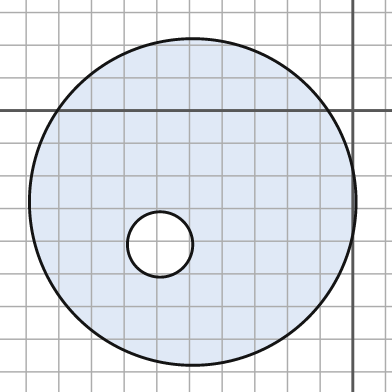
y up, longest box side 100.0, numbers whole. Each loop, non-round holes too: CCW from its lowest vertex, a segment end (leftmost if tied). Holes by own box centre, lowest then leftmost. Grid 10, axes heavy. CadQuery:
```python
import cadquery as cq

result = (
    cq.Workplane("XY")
    .moveTo(-49.0, -28.0)
    .circle(50.0)
    .moveTo(-59.0, -41.0)
    .circle(10.0)
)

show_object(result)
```